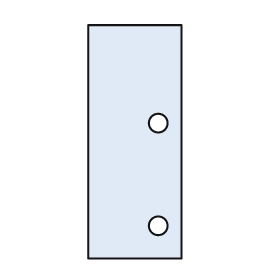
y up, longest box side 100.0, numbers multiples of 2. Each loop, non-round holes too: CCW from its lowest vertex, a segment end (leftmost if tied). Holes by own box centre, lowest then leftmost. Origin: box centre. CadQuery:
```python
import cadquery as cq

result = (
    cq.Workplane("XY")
    .moveTo(-20.0, -50.0)
    .lineTo(20.0, -50.0)
    .lineTo(20.0, 50.0)
    .lineTo(-20.0, 50.0)
    .close()
    .moveTo(10.0, -36.0)
    .circle(4.0)
    .moveTo(10.0, 8.0)
    .circle(4.0)
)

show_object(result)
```